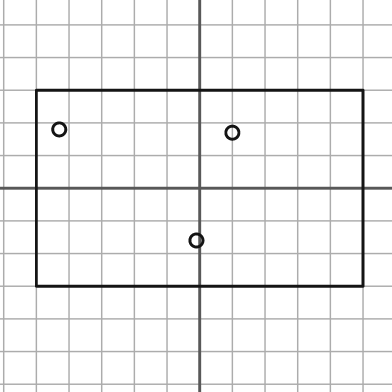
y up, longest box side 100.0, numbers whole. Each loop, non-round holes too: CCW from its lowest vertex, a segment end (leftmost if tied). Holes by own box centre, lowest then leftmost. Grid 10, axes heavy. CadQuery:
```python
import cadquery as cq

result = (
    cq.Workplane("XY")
    .moveTo(-50.0, -30.0)
    .lineTo(50.0, -30.0)
    .lineTo(50.0, 30.0)
    .lineTo(-50.0, 30.0)
    .close()
    .moveTo(-1.0, -16.0)
    .circle(2.0)
    .moveTo(10.0, 17.0)
    .circle(2.0)
    .moveTo(-43.0, 18.0)
    .circle(2.0)
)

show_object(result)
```